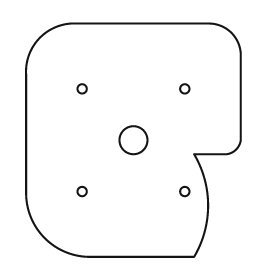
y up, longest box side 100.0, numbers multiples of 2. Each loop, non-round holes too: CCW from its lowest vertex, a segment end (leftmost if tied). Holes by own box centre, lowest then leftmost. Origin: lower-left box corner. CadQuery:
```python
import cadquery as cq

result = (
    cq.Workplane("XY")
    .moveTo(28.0, 0.0)
    .lineTo(72.0, 0.0)
    .threePointArc((78.0, 22.0), (72.0, 44.0))
    .lineTo(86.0, 44.0)
    .threePointArc((90.0, 46.0), (92.0, 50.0))
    .lineTo(92.0, 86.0)
    .threePointArc((88.0, 96.0), (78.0, 100.0))
    .lineTo(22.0, 100.0)
    .threePointArc((6.0, 94.0), (0.0, 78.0))
    .lineTo(0.0, 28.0)
    .threePointArc((8.0, 8.0), (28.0, 0.0))
    .close()
    .moveTo(24.0, 28.0)
    .circle(2.0)
    .moveTo(68.0, 28.0)
    .circle(2.0)
    .moveTo(46.0, 50.0)
    .circle(6.0)
    .moveTo(24.0, 72.0)
    .circle(2.0)
    .moveTo(68.0, 72.0)
    .circle(2.0)
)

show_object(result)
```